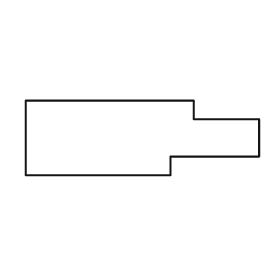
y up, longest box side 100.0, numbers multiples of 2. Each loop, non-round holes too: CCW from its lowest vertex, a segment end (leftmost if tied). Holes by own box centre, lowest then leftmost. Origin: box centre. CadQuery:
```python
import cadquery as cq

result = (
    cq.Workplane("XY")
    .moveTo(-50.0, -16.0)
    .lineTo(12.0, -16.0)
    .lineTo(12.0, -8.0)
    .lineTo(50.0, -8.0)
    .lineTo(50.0, 8.0)
    .lineTo(22.0, 8.0)
    .lineTo(22.0, 16.0)
    .lineTo(-50.0, 16.0)
    .close()
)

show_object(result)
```